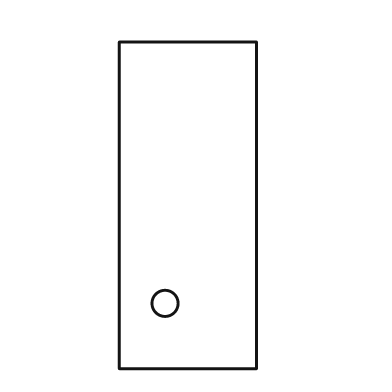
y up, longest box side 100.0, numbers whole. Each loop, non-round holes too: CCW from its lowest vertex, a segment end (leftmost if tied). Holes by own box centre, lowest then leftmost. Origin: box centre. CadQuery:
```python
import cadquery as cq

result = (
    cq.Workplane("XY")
    .moveTo(-21.0, -50.0)
    .lineTo(21.0, -50.0)
    .lineTo(21.0, 50.0)
    .lineTo(-21.0, 50.0)
    .close()
    .moveTo(-7.0, -30.0)
    .circle(4.0)
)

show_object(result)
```